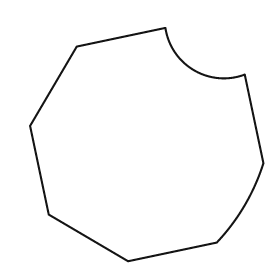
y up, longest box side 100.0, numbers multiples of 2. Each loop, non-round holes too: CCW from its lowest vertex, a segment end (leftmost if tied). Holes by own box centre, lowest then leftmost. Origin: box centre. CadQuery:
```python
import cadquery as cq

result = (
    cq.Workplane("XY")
    .moveTo(-8.0, -50.0)
    .lineTo(30.0, -42.0)
    .threePointArc((42.0, -26.0), (50.0, -8.0))
    .lineTo(42.0, 30.0)
    .threePointArc((20.0, 32.0), (8.0, 50.0))
    .lineTo(-30.0, 42.0)
    .lineTo(-50.0, 8.0)
    .lineTo(-42.0, -30.0)
    .close()
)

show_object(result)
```